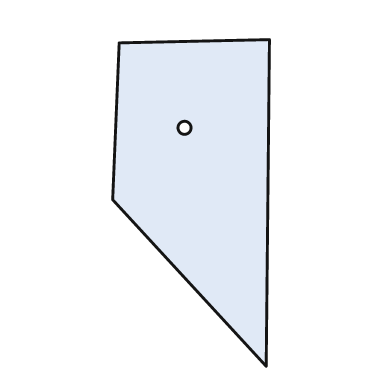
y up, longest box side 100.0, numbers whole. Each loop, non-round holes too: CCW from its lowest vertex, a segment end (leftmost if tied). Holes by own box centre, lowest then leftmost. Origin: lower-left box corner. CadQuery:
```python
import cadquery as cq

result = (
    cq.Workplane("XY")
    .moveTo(47.0, 0.0)
    .lineTo(48.0, 100.0)
    .lineTo(2.0, 99.0)
    .lineTo(0.0, 51.0)
    .close()
    .moveTo(22.0, 73.0)
    .circle(2.0)
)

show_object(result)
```